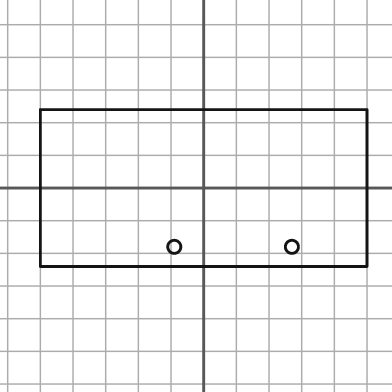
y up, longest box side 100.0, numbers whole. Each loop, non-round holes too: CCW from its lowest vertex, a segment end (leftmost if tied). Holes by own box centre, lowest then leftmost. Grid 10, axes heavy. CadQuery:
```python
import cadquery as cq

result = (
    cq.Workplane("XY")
    .moveTo(-50.0, -24.0)
    .lineTo(50.0, -24.0)
    .lineTo(50.0, 24.0)
    .lineTo(-50.0, 24.0)
    .close()
    .moveTo(-9.0, -18.0)
    .circle(2.0)
    .moveTo(27.0, -18.0)
    .circle(2.0)
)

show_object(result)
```